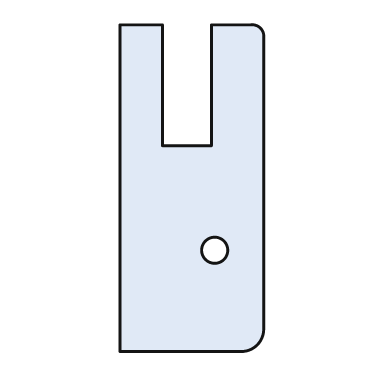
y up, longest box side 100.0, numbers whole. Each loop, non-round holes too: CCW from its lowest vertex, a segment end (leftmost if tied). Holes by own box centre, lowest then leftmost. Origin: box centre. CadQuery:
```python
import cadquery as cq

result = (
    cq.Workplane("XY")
    .moveTo(-22.0, -50.0)
    .lineTo(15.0, -50.0)
    .threePointArc((20.0, -48.0), (22.0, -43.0))
    .lineTo(22.0, 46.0)
    .threePointArc((21.0, 49.0), (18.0, 50.0))
    .lineTo(6.0, 50.0)
    .lineTo(6.0, 13.0)
    .lineTo(-9.0, 13.0)
    .lineTo(-9.0, 50.0)
    .lineTo(-22.0, 50.0)
    .close()
    .moveTo(7.0, -19.0)
    .circle(4.0)
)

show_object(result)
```